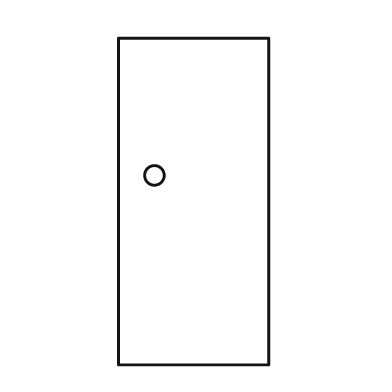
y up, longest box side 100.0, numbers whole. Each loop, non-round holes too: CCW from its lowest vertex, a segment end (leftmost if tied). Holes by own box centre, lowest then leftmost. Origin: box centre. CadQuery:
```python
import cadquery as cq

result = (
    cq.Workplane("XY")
    .moveTo(-23.0, -50.0)
    .lineTo(23.0, -50.0)
    .lineTo(23.0, 50.0)
    .lineTo(-23.0, 50.0)
    .close()
    .moveTo(-12.0, 8.0)
    .circle(3.0)
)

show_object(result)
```